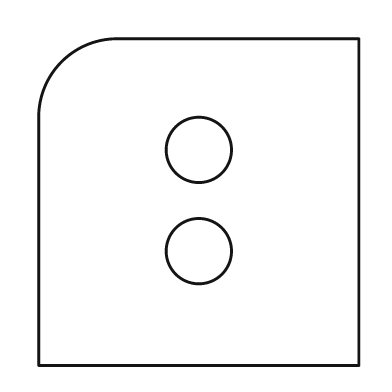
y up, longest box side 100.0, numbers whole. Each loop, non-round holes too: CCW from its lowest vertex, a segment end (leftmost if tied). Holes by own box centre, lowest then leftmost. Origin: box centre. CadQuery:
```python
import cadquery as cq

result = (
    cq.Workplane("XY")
    .moveTo(-49.0, -50.0)
    .lineTo(49.0, -50.0)
    .lineTo(49.0, 50.0)
    .lineTo(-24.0, 50.0)
    .threePointArc((-42.0, 43.0), (-49.0, 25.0))
    .close()
    .moveTo(0.0, -15.0)
    .circle(10.0)
    .moveTo(0.0, 16.0)
    .circle(10.0)
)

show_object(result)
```